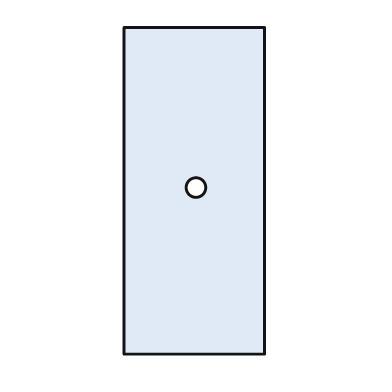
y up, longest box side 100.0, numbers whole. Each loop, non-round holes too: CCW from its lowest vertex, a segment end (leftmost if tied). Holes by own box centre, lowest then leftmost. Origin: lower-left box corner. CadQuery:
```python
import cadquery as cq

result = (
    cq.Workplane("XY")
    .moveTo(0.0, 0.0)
    .lineTo(43.0, 0.0)
    .lineTo(43.0, 100.0)
    .lineTo(0.0, 100.0)
    .close()
    .moveTo(22.0, 51.0)
    .circle(3.0)
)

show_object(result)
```